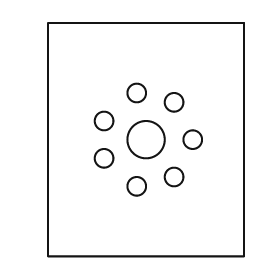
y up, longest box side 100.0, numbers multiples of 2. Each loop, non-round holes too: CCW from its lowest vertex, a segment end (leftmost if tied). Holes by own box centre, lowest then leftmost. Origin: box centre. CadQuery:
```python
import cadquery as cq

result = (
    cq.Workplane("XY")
    .moveTo(-42.0, -50.0)
    .lineTo(42.0, -50.0)
    .lineTo(42.0, 50.0)
    .lineTo(-42.0, 50.0)
    .close()
    .moveTo(-4.0, -20.0)
    .circle(4.0)
    .moveTo(12.0, -16.0)
    .circle(4.0)
    .moveTo(-18.0, -8.0)
    .circle(4.0)
    .moveTo(0.0, 0.0)
    .circle(8.0)
    .moveTo(20.0, 0.0)
    .circle(4.0)
    .moveTo(-18.0, 8.0)
    .circle(4.0)
    .moveTo(12.0, 16.0)
    .circle(4.0)
    .moveTo(-4.0, 20.0)
    .circle(4.0)
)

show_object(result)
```